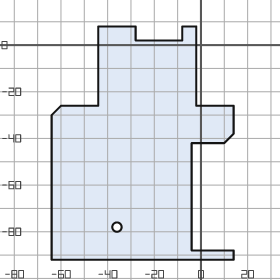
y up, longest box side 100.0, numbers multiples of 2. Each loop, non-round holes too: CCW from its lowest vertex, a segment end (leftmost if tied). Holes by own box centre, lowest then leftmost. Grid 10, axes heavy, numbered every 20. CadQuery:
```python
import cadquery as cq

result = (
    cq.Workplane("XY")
    .moveTo(-64.0, -92.0)
    .lineTo(14.0, -92.0)
    .lineTo(14.0, -88.0)
    .lineTo(-4.0, -88.0)
    .lineTo(-4.0, -42.0)
    .lineTo(10.0, -42.0)
    .lineTo(14.0, -38.0)
    .lineTo(14.0, -26.0)
    .lineTo(-2.0, -26.0)
    .lineTo(-2.0, 8.0)
    .lineTo(-8.0, 8.0)
    .lineTo(-8.0, 2.0)
    .lineTo(-28.0, 2.0)
    .lineTo(-28.0, 8.0)
    .lineTo(-44.0, 8.0)
    .lineTo(-44.0, -26.0)
    .lineTo(-60.0, -26.0)
    .lineTo(-64.0, -30.0)
    .close()
    .moveTo(-36.0, -78.0)
    .circle(2.0)
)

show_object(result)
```